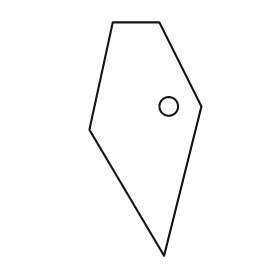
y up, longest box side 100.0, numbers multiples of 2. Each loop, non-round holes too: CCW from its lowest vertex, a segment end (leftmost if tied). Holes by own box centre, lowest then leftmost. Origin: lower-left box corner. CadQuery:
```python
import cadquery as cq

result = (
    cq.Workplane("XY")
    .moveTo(32.0, 0.0)
    .lineTo(48.0, 64.0)
    .lineTo(30.0, 100.0)
    .lineTo(10.0, 100.0)
    .lineTo(0.0, 54.0)
    .close()
    .moveTo(34.0, 64.0)
    .circle(4.0)
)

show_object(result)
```